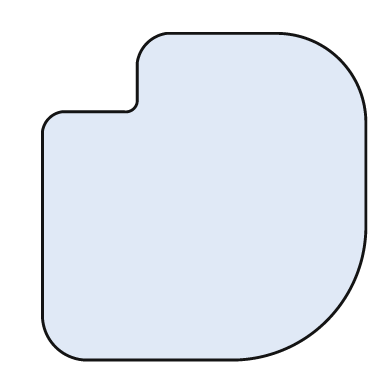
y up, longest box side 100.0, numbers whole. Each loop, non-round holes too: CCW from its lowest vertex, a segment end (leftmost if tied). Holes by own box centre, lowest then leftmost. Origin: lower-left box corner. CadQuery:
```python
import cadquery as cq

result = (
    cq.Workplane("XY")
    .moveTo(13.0, 0.0)
    .lineTo(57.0, 0.0)
    .threePointArc((87.0, 12.0), (99.0, 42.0))
    .lineTo(99.0, 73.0)
    .threePointArc((91.0, 92.0), (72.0, 100.0))
    .lineTo(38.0, 100.0)
    .threePointArc((32.0, 97.0), (29.0, 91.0))
    .lineTo(29.0, 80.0)
    .threePointArc((28.0, 77.0), (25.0, 76.0))
    .lineTo(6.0, 76.0)
    .threePointArc((2.0, 74.0), (0.0, 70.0))
    .lineTo(0.0, 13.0)
    .threePointArc((4.0, 4.0), (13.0, 0.0))
    .close()
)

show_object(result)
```